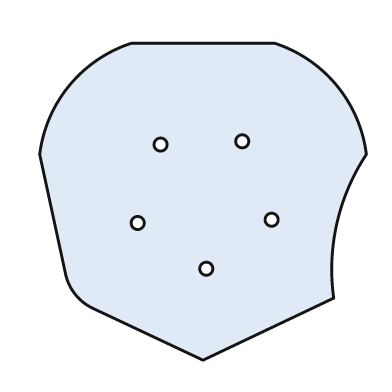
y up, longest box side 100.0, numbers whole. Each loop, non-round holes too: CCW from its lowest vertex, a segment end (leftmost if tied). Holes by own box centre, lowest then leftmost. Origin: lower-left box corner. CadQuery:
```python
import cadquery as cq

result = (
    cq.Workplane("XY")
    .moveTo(50.0, 0.0)
    .lineTo(90.0, 19.0)
    .threePointArc((91.0, 42.0), (100.0, 63.0))
    .threePointArc((91.0, 84.0), (72.0, 97.0))
    .lineTo(28.0, 97.0)
    .threePointArc((9.0, 84.0), (0.0, 63.0))
    .lineTo(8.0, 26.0)
    .threePointArc((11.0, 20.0), (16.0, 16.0))
    .close()
    .moveTo(51.0, 28.0)
    .circle(2.0)
    .moveTo(30.0, 42.0)
    .circle(2.0)
    .moveTo(71.0, 43.0)
    .circle(2.0)
    .moveTo(37.0, 66.0)
    .circle(2.0)
    .moveTo(62.0, 67.0)
    .circle(2.0)
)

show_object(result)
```